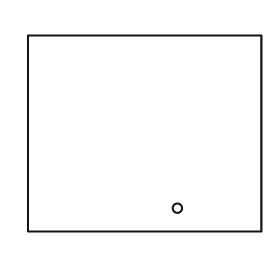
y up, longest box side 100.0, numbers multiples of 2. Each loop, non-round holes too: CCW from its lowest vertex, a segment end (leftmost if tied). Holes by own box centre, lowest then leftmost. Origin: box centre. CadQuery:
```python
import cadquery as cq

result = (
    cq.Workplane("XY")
    .moveTo(-50.0, -42.0)
    .lineTo(50.0, -42.0)
    .lineTo(50.0, 42.0)
    .lineTo(-50.0, 42.0)
    .close()
    .moveTo(14.0, -32.0)
    .circle(2.0)
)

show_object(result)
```